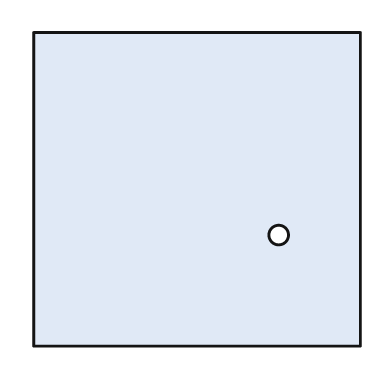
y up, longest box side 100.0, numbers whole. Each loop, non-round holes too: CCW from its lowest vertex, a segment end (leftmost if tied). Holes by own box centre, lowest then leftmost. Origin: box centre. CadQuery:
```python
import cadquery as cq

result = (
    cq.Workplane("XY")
    .moveTo(-50.0, -48.0)
    .lineTo(50.0, -48.0)
    .lineTo(50.0, 48.0)
    .lineTo(-50.0, 48.0)
    .close()
    .moveTo(25.0, -14.0)
    .circle(3.0)
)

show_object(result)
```